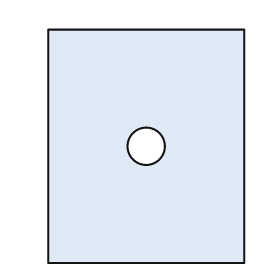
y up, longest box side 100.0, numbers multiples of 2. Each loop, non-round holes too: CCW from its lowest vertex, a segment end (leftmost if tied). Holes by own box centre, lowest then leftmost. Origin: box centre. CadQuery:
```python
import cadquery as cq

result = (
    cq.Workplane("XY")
    .moveTo(-42.0, -50.0)
    .lineTo(42.0, -50.0)
    .lineTo(42.0, 50.0)
    .lineTo(-42.0, 50.0)
    .close()
    .moveTo(0.0, 0.0)
    .circle(8.0)
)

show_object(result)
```